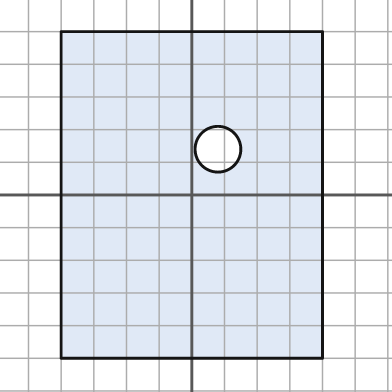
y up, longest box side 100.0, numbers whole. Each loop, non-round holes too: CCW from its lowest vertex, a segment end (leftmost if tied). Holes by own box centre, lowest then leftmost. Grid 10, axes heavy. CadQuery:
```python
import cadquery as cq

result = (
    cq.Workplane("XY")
    .moveTo(-40.0, -50.0)
    .lineTo(40.0, -50.0)
    .lineTo(40.0, 50.0)
    .lineTo(-40.0, 50.0)
    .close()
    .moveTo(8.0, 14.0)
    .circle(7.0)
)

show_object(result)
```